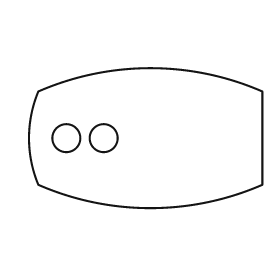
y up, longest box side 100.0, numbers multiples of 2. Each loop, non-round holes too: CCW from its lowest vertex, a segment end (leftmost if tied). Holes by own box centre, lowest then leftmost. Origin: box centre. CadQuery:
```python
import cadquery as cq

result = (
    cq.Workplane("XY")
    .moveTo(-46.0, -20.0)
    .threePointArc((2.0, -30.0), (50.0, -20.0))
    .lineTo(50.0, 20.0)
    .threePointArc((2.0, 30.0), (-46.0, 20.0))
    .threePointArc((-50.0, 0.0), (-46.0, -20.0))
    .close()
    .moveTo(-34.0, 0.0)
    .circle(6.0)
    .moveTo(-18.0, 0.0)
    .circle(6.0)
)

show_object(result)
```